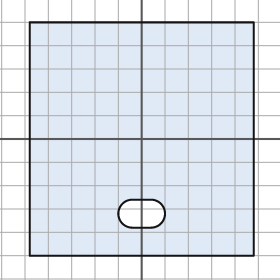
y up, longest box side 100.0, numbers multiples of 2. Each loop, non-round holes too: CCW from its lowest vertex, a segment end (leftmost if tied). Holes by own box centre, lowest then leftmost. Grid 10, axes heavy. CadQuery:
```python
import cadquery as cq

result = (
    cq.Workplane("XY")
    .moveTo(-48.0, -50.0)
    .lineTo(48.0, -50.0)
    .lineTo(48.0, 50.0)
    .lineTo(-48.0, 50.0)
    .close()
    .moveTo(-4.0, -38.0)
    .lineTo(4.0, -38.0)
    .threePointArc((10.0, -32.0), (4.0, -26.0))
    .lineTo(-4.0, -26.0)
    .threePointArc((-10.0, -32.0), (-4.0, -38.0))
    .close()
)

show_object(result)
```